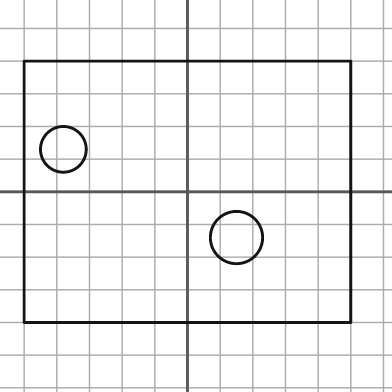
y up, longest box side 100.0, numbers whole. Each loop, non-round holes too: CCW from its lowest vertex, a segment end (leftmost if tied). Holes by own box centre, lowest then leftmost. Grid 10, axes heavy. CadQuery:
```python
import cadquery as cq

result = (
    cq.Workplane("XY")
    .moveTo(-50.0, -40.0)
    .lineTo(50.0, -40.0)
    .lineTo(50.0, 40.0)
    .lineTo(-50.0, 40.0)
    .close()
    .moveTo(15.0, -14.0)
    .circle(8.0)
    .moveTo(-38.0, 13.0)
    .circle(7.0)
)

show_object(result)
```